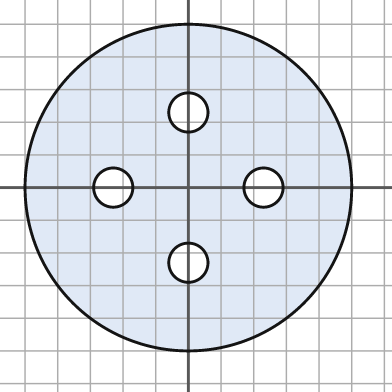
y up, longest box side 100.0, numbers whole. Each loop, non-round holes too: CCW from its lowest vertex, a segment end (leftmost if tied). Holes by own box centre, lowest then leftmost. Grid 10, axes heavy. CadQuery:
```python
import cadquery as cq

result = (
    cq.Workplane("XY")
    .moveTo(0.0, 0.0)
    .circle(50.0)
    .moveTo(0.0, -23.0)
    .circle(6.0)
    .moveTo(-23.0, 0.0)
    .circle(6.0)
    .moveTo(23.0, 0.0)
    .circle(6.0)
    .moveTo(0.0, 23.0)
    .circle(6.0)
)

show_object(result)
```